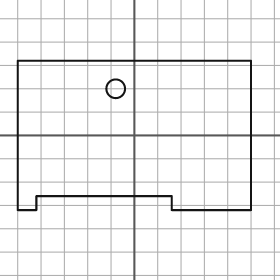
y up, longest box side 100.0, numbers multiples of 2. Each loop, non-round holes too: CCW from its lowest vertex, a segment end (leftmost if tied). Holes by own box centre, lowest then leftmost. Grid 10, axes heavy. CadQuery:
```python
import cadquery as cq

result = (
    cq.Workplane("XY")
    .moveTo(-50.0, -32.0)
    .lineTo(-42.0, -32.0)
    .lineTo(-42.0, -26.0)
    .lineTo(16.0, -26.0)
    .lineTo(16.0, -32.0)
    .lineTo(50.0, -32.0)
    .lineTo(50.0, 32.0)
    .lineTo(-50.0, 32.0)
    .close()
    .moveTo(-8.0, 20.0)
    .circle(4.0)
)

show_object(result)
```